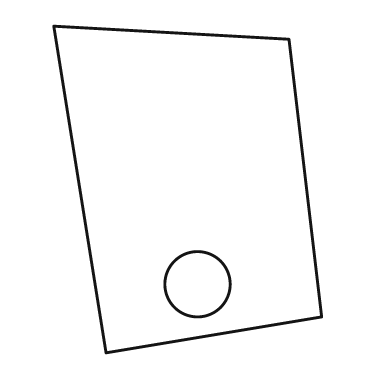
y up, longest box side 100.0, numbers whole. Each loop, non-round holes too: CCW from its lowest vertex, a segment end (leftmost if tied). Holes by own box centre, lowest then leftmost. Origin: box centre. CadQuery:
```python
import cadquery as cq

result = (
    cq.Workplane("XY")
    .moveTo(-25.0, -50.0)
    .lineTo(41.0, -39.0)
    .lineTo(31.0, 46.0)
    .lineTo(-41.0, 50.0)
    .close()
    .moveTo(3.0, -29.0)
    .circle(10.0)
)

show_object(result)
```